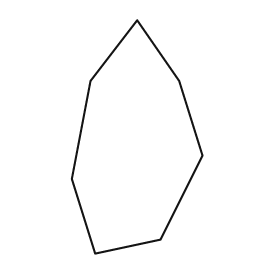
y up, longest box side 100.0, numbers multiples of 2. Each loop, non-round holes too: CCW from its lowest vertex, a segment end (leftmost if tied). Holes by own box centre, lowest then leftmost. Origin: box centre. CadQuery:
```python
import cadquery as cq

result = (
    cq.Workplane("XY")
    .moveTo(-18.0, -50.0)
    .lineTo(10.0, -44.0)
    .lineTo(28.0, -8.0)
    .lineTo(18.0, 24.0)
    .lineTo(0.0, 50.0)
    .lineTo(-20.0, 24.0)
    .lineTo(-28.0, -18.0)
    .close()
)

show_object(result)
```